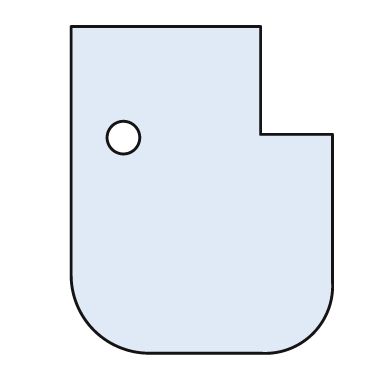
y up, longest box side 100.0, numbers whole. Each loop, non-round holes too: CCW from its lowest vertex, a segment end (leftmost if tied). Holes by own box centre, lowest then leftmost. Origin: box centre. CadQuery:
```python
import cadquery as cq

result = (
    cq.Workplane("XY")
    .moveTo(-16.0, -50.0)
    .lineTo(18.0, -50.0)
    .threePointArc((34.0, -44.0), (40.0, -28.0))
    .lineTo(40.0, 17.0)
    .lineTo(18.0, 17.0)
    .lineTo(18.0, 50.0)
    .lineTo(-40.0, 50.0)
    .lineTo(-40.0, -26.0)
    .threePointArc((-33.0, -43.0), (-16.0, -50.0))
    .close()
    .moveTo(-24.0, 16.0)
    .circle(5.0)
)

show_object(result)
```